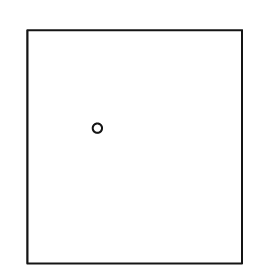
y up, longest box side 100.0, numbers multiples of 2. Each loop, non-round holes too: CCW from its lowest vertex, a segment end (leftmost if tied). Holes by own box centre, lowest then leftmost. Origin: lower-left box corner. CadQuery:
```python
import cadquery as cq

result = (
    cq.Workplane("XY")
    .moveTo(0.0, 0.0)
    .lineTo(92.0, 0.0)
    .lineTo(92.0, 100.0)
    .lineTo(0.0, 100.0)
    .close()
    .moveTo(30.0, 58.0)
    .circle(2.0)
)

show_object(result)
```